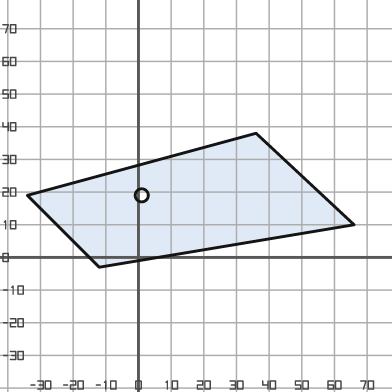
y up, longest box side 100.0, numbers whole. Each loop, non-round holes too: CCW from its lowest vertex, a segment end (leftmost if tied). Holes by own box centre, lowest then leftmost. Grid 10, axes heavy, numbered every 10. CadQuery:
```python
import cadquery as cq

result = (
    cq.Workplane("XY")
    .moveTo(-12.0, -3.0)
    .lineTo(66.0, 10.0)
    .lineTo(36.0, 38.0)
    .lineTo(-34.0, 19.0)
    .close()
    .moveTo(1.0, 19.0)
    .circle(2.0)
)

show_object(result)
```